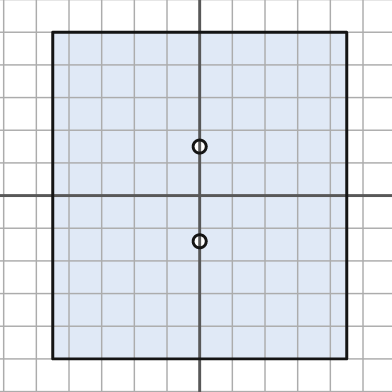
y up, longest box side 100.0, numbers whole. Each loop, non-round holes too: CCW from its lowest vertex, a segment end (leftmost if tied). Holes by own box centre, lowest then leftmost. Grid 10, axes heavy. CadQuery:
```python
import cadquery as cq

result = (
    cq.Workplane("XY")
    .moveTo(-45.0, -50.0)
    .lineTo(45.0, -50.0)
    .lineTo(45.0, 50.0)
    .lineTo(-45.0, 50.0)
    .close()
    .moveTo(0.0, -14.0)
    .circle(2.0)
    .moveTo(0.0, 15.0)
    .circle(2.0)
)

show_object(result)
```